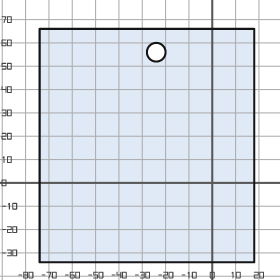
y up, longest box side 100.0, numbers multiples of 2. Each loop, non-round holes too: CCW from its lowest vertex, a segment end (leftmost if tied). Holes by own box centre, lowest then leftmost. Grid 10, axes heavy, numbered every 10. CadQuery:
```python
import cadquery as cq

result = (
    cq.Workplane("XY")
    .moveTo(-74.0, -34.0)
    .lineTo(18.0, -34.0)
    .lineTo(18.0, 66.0)
    .lineTo(-74.0, 66.0)
    .close()
    .moveTo(-24.0, 56.0)
    .circle(4.0)
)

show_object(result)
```